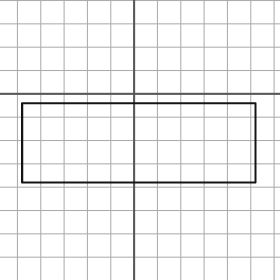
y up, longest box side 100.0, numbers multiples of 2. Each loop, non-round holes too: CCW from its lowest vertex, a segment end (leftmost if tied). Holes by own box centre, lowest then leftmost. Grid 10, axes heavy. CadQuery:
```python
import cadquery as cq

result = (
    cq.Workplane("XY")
    .moveTo(-48.0, -38.0)
    .lineTo(52.0, -38.0)
    .lineTo(52.0, -4.0)
    .lineTo(-48.0, -4.0)
    .close()
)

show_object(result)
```